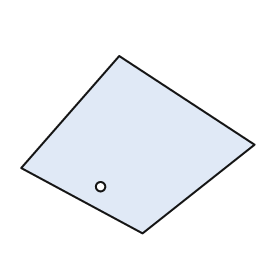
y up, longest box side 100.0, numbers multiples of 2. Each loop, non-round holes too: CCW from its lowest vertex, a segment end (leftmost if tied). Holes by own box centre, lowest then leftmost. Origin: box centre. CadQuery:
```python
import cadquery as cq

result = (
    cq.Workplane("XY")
    .moveTo(2.0, -38.0)
    .lineTo(50.0, 0.0)
    .lineTo(-8.0, 38.0)
    .lineTo(-50.0, -10.0)
    .close()
    .moveTo(-16.0, -18.0)
    .circle(2.0)
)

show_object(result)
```